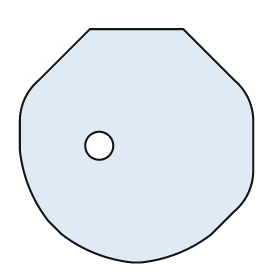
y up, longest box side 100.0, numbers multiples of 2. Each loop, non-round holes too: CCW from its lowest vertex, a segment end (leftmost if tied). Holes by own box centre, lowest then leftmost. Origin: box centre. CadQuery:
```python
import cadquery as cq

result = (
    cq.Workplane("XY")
    .moveTo(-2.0, -50.0)
    .lineTo(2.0, -50.0)
    .threePointArc((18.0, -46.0), (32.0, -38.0))
    .lineTo(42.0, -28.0)
    .threePointArc((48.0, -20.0), (50.0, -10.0))
    .lineTo(50.0, 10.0)
    .threePointArc((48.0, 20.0), (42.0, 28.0))
    .lineTo(20.0, 50.0)
    .lineTo(-20.0, 50.0)
    .lineTo(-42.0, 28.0)
    .threePointArc((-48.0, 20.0), (-50.0, 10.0))
    .lineTo(-50.0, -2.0)
    .threePointArc((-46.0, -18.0), (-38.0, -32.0))
    .lineTo(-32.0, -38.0)
    .threePointArc((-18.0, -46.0), (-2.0, -50.0))
    .close()
    .moveTo(-16.0, 0.0)
    .circle(6.0)
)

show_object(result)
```